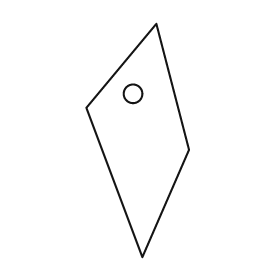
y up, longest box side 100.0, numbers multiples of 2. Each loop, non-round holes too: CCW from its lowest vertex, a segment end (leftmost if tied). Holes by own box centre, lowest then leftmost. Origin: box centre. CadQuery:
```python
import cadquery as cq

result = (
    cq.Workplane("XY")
    .moveTo(2.0, -50.0)
    .lineTo(22.0, -4.0)
    .lineTo(8.0, 50.0)
    .lineTo(-22.0, 14.0)
    .close()
    .moveTo(-2.0, 20.0)
    .circle(4.0)
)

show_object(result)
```